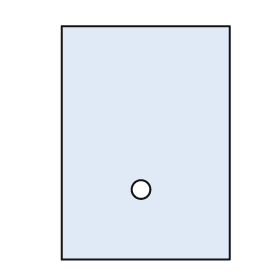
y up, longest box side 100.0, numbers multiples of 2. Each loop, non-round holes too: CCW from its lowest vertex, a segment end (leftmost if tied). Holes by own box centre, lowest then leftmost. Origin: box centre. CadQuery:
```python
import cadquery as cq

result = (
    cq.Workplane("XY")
    .moveTo(-36.0, -50.0)
    .lineTo(36.0, -50.0)
    .lineTo(36.0, 50.0)
    .lineTo(-36.0, 50.0)
    .close()
    .moveTo(-2.0, -20.0)
    .circle(4.0)
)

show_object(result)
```